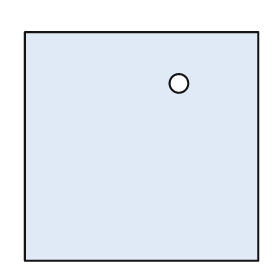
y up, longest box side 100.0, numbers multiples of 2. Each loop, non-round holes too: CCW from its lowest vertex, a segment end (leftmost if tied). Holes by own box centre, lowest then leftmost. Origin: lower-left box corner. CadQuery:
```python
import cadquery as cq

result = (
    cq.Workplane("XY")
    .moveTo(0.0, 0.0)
    .lineTo(100.0, 0.0)
    .lineTo(100.0, 98.0)
    .lineTo(0.0, 98.0)
    .close()
    .moveTo(66.0, 76.0)
    .circle(4.0)
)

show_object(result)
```